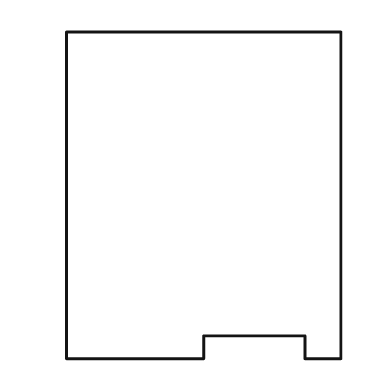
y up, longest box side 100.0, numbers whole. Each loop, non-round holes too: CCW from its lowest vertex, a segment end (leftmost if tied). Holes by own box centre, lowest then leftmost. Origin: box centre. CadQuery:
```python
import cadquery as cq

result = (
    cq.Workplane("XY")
    .moveTo(-42.0, -50.0)
    .lineTo(0.0, -50.0)
    .lineTo(0.0, -43.0)
    .lineTo(31.0, -43.0)
    .lineTo(31.0, -50.0)
    .lineTo(42.0, -50.0)
    .lineTo(42.0, 50.0)
    .lineTo(-42.0, 50.0)
    .close()
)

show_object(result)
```